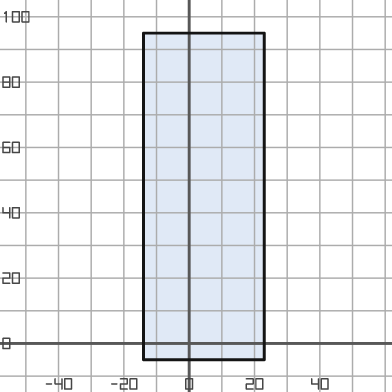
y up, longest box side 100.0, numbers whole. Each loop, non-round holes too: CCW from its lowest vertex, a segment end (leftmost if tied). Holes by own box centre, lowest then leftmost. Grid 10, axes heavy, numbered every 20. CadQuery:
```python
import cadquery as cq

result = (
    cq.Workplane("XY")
    .moveTo(-14.0, -5.0)
    .lineTo(23.0, -5.0)
    .lineTo(23.0, 95.0)
    .lineTo(-14.0, 95.0)
    .close()
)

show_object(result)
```